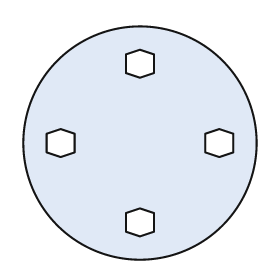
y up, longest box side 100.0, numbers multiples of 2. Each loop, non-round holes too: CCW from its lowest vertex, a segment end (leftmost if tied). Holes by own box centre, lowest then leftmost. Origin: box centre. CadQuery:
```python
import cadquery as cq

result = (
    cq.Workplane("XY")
    .moveTo(0.0, 0.0)
    .circle(50.0)
    .moveTo(0.0, -40.0)
    .lineTo(6.0, -38.0)
    .lineTo(6.0, -30.0)
    .lineTo(0.0, -28.0)
    .lineTo(-6.0, -30.0)
    .lineTo(-6.0, -38.0)
    .close()
    .moveTo(-34.0, -6.0)
    .lineTo(-28.0, -4.0)
    .lineTo(-28.0, 4.0)
    .lineTo(-34.0, 6.0)
    .lineTo(-40.0, 4.0)
    .lineTo(-40.0, -4.0)
    .close()
    .moveTo(34.0, -6.0)
    .lineTo(40.0, -4.0)
    .lineTo(40.0, 4.0)
    .lineTo(34.0, 6.0)
    .lineTo(28.0, 4.0)
    .lineTo(28.0, -4.0)
    .close()
    .moveTo(0.0, 28.0)
    .lineTo(6.0, 30.0)
    .lineTo(6.0, 38.0)
    .lineTo(0.0, 40.0)
    .lineTo(-6.0, 38.0)
    .lineTo(-6.0, 30.0)
    .close()
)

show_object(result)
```